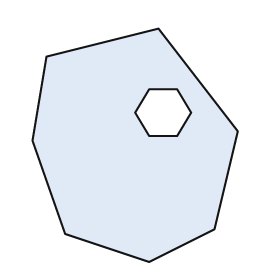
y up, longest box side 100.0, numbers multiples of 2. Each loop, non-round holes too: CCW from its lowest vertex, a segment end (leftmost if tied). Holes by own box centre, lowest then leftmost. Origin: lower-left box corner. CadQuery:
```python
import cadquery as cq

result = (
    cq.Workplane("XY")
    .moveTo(50.0, 0.0)
    .lineTo(78.0, 14.0)
    .lineTo(88.0, 56.0)
    .lineTo(54.0, 100.0)
    .lineTo(6.0, 88.0)
    .lineTo(0.0, 52.0)
    .lineTo(14.0, 12.0)
    .close()
    .moveTo(50.0, 54.0)
    .lineTo(62.0, 54.0)
    .lineTo(68.0, 64.0)
    .lineTo(62.0, 74.0)
    .lineTo(50.0, 74.0)
    .lineTo(44.0, 64.0)
    .close()
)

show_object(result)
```